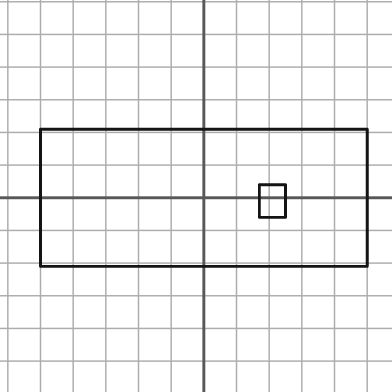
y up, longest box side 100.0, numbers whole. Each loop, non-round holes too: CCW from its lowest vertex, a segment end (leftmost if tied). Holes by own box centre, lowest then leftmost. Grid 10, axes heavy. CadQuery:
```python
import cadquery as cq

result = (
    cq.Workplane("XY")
    .moveTo(-50.0, -21.0)
    .lineTo(50.0, -21.0)
    .lineTo(50.0, 21.0)
    .lineTo(-50.0, 21.0)
    .close()
    .moveTo(17.0, -6.0)
    .lineTo(25.0, -6.0)
    .lineTo(25.0, 4.0)
    .lineTo(17.0, 4.0)
    .close()
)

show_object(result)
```